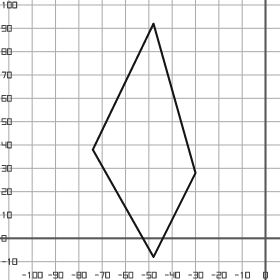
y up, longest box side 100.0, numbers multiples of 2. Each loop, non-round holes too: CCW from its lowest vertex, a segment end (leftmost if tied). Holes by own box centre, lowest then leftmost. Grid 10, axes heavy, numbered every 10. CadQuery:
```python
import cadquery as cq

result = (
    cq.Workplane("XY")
    .moveTo(-48.0, -8.0)
    .lineTo(-30.0, 28.0)
    .lineTo(-48.0, 92.0)
    .lineTo(-74.0, 38.0)
    .close()
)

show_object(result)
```